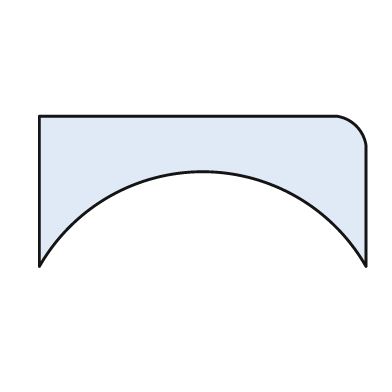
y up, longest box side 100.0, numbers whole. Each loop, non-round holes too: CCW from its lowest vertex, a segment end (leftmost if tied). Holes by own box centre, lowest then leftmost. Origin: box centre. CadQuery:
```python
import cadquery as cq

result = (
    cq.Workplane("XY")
    .moveTo(-50.0, -23.0)
    .threePointArc((0.0, 6.0), (50.0, -23.0))
    .lineTo(50.0, 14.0)
    .threePointArc((47.0, 20.0), (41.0, 23.0))
    .lineTo(-50.0, 23.0)
    .close()
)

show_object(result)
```